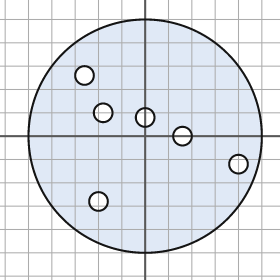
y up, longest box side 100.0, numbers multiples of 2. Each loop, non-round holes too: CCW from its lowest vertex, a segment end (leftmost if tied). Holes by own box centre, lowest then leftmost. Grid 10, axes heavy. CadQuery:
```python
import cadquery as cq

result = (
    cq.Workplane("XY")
    .moveTo(0.0, 0.0)
    .circle(50.0)
    .moveTo(-20.0, -28.0)
    .circle(4.0)
    .moveTo(40.0, -12.0)
    .circle(4.0)
    .moveTo(16.0, 0.0)
    .circle(4.0)
    .moveTo(0.0, 8.0)
    .circle(4.0)
    .moveTo(-18.0, 10.0)
    .circle(4.0)
    .moveTo(-26.0, 26.0)
    .circle(4.0)
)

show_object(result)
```